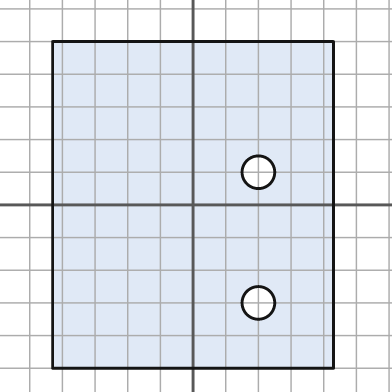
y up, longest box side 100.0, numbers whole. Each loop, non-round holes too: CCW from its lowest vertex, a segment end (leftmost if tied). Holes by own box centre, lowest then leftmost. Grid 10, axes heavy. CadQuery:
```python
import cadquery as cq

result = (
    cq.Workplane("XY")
    .moveTo(-43.0, -50.0)
    .lineTo(43.0, -50.0)
    .lineTo(43.0, 50.0)
    .lineTo(-43.0, 50.0)
    .close()
    .moveTo(20.0, -30.0)
    .circle(5.0)
    .moveTo(20.0, 10.0)
    .circle(5.0)
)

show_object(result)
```